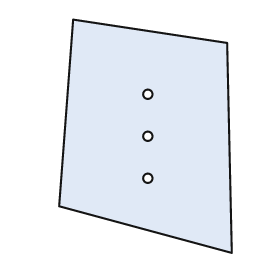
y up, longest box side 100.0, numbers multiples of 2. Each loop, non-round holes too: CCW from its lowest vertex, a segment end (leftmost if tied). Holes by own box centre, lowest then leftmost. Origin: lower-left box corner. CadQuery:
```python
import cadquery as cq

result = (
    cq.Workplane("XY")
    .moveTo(74.0, 0.0)
    .lineTo(72.0, 90.0)
    .lineTo(6.0, 100.0)
    .lineTo(0.0, 20.0)
    .close()
    .moveTo(38.0, 32.0)
    .circle(2.0)
    .moveTo(38.0, 50.0)
    .circle(2.0)
    .moveTo(38.0, 68.0)
    .circle(2.0)
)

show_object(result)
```